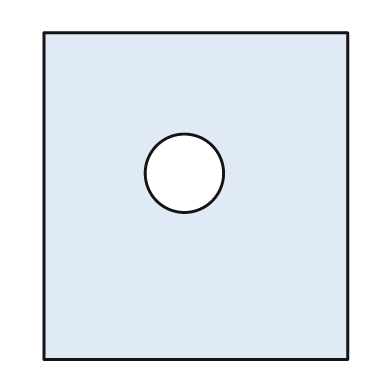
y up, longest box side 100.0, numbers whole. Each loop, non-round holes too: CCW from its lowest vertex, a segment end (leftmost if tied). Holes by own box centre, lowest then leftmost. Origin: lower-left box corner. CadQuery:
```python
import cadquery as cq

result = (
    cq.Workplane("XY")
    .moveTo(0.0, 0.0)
    .lineTo(93.0, 0.0)
    .lineTo(93.0, 100.0)
    .lineTo(0.0, 100.0)
    .close()
    .moveTo(43.0, 57.0)
    .circle(12.0)
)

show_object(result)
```